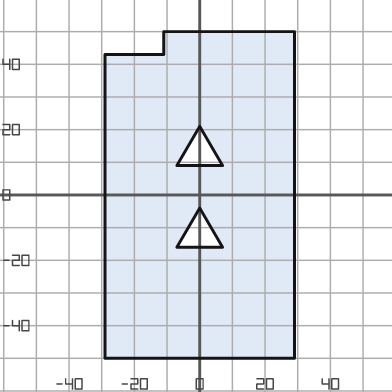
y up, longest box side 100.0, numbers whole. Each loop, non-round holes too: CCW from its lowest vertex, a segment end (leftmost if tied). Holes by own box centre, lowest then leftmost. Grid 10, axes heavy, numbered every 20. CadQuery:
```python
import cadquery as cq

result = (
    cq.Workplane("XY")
    .moveTo(-29.0, -50.0)
    .lineTo(29.0, -50.0)
    .lineTo(29.0, 50.0)
    .lineTo(-11.0, 50.0)
    .lineTo(-11.0, 43.0)
    .lineTo(-29.0, 43.0)
    .close()
    .moveTo(-7.0, -16.0)
    .lineTo(7.0, -16.0)
    .lineTo(0.0, -4.0)
    .close()
    .moveTo(-7.0, 9.0)
    .lineTo(7.0, 9.0)
    .lineTo(0.0, 21.0)
    .close()
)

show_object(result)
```